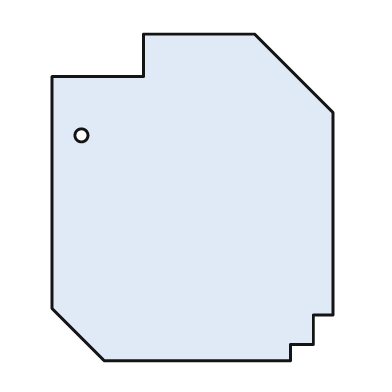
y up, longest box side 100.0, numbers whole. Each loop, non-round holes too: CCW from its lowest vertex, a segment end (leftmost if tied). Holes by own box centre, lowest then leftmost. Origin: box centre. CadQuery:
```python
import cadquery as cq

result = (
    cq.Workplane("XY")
    .moveTo(-27.0, -50.0)
    .lineTo(30.0, -50.0)
    .lineTo(30.0, -45.0)
    .lineTo(37.0, -45.0)
    .lineTo(37.0, -36.0)
    .lineTo(43.0, -36.0)
    .lineTo(43.0, 26.0)
    .lineTo(19.0, 50.0)
    .lineTo(-15.0, 50.0)
    .lineTo(-15.0, 37.0)
    .lineTo(-43.0, 37.0)
    .lineTo(-43.0, -34.0)
    .close()
    .moveTo(-34.0, 19.0)
    .circle(2.0)
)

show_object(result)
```